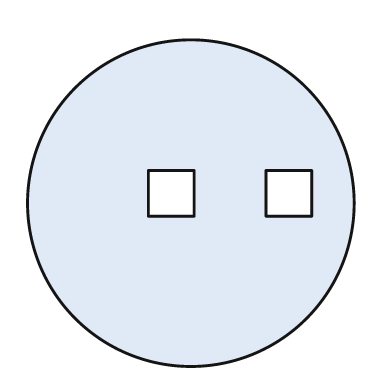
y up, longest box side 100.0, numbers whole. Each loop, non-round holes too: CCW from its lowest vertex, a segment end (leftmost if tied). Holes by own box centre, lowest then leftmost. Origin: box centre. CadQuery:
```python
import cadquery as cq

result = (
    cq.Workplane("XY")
    .moveTo(0.0, 0.0)
    .circle(50.0)
    .moveTo(-13.0, -4.0)
    .lineTo(1.0, -4.0)
    .lineTo(1.0, 10.0)
    .lineTo(-13.0, 10.0)
    .close()
    .moveTo(23.0, -4.0)
    .lineTo(37.0, -4.0)
    .lineTo(37.0, 10.0)
    .lineTo(23.0, 10.0)
    .close()
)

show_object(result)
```